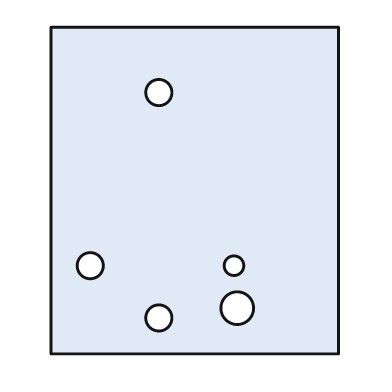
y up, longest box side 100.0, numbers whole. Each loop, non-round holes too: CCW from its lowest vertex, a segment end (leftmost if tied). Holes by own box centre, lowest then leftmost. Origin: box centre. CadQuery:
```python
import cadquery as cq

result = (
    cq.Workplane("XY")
    .moveTo(-44.0, -50.0)
    .lineTo(44.0, -50.0)
    .lineTo(44.0, 50.0)
    .lineTo(-44.0, 50.0)
    .close()
    .moveTo(-11.0, -39.0)
    .circle(4.0)
    .moveTo(13.0, -36.0)
    .circle(5.0)
    .moveTo(-32.0, -23.0)
    .circle(4.0)
    .moveTo(12.0, -23.0)
    .circle(3.0)
    .moveTo(-11.0, 30.0)
    .circle(4.0)
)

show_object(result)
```